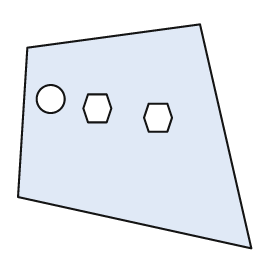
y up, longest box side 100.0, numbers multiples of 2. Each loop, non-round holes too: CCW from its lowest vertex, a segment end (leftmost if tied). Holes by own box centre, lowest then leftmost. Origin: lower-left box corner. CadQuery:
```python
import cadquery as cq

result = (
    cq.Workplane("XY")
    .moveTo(100.0, 0.0)
    .lineTo(78.0, 96.0)
    .lineTo(4.0, 86.0)
    .lineTo(0.0, 22.0)
    .close()
    .moveTo(56.0, 50.0)
    .lineTo(64.0, 50.0)
    .lineTo(66.0, 56.0)
    .lineTo(64.0, 62.0)
    .lineTo(56.0, 62.0)
    .lineTo(54.0, 56.0)
    .close()
    .moveTo(30.0, 54.0)
    .lineTo(38.0, 54.0)
    .lineTo(40.0, 60.0)
    .lineTo(38.0, 66.0)
    .lineTo(30.0, 66.0)
    .lineTo(28.0, 60.0)
    .close()
    .moveTo(14.0, 64.0)
    .circle(6.0)
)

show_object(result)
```